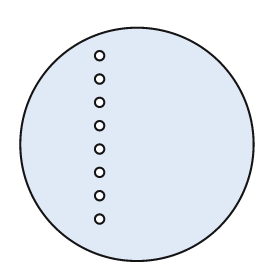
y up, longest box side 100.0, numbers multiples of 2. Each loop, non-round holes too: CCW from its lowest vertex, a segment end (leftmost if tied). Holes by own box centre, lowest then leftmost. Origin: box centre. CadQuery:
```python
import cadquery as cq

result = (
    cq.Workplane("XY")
    .moveTo(0.0, 0.0)
    .circle(50.0)
    .moveTo(-16.0, -32.0)
    .circle(2.0)
    .moveTo(-16.0, -22.0)
    .circle(2.0)
    .moveTo(-16.0, -12.0)
    .circle(2.0)
    .moveTo(-16.0, -2.0)
    .circle(2.0)
    .moveTo(-16.0, 8.0)
    .circle(2.0)
    .moveTo(-16.0, 18.0)
    .circle(2.0)
    .moveTo(-16.0, 28.0)
    .circle(2.0)
    .moveTo(-16.0, 38.0)
    .circle(2.0)
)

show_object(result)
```